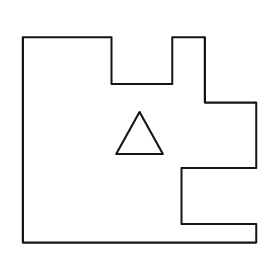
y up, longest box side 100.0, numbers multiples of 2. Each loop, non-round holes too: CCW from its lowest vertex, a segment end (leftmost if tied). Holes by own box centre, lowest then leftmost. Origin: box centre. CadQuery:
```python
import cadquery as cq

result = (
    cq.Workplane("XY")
    .moveTo(-50.0, -44.0)
    .lineTo(50.0, -44.0)
    .lineTo(50.0, -36.0)
    .lineTo(18.0, -36.0)
    .lineTo(18.0, -12.0)
    .lineTo(50.0, -12.0)
    .lineTo(50.0, 16.0)
    .lineTo(28.0, 16.0)
    .lineTo(28.0, 44.0)
    .lineTo(14.0, 44.0)
    .lineTo(14.0, 24.0)
    .lineTo(-12.0, 24.0)
    .lineTo(-12.0, 44.0)
    .lineTo(-50.0, 44.0)
    .close()
    .moveTo(-10.0, -6.0)
    .lineTo(10.0, -6.0)
    .lineTo(0.0, 12.0)
    .close()
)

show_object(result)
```